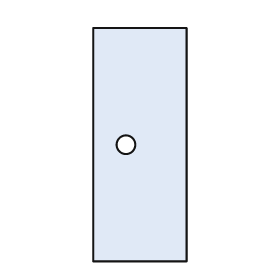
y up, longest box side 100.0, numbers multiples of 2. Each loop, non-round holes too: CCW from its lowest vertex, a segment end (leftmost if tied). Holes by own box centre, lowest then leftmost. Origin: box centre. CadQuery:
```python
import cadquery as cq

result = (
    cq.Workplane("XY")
    .moveTo(-20.0, -50.0)
    .lineTo(20.0, -50.0)
    .lineTo(20.0, 50.0)
    .lineTo(-20.0, 50.0)
    .close()
    .moveTo(-6.0, 0.0)
    .circle(4.0)
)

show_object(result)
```